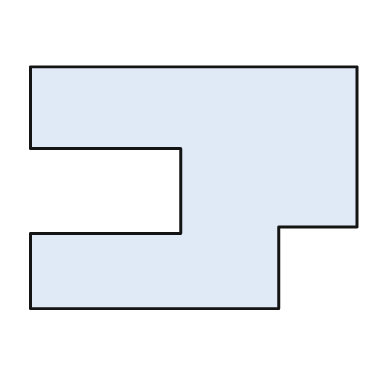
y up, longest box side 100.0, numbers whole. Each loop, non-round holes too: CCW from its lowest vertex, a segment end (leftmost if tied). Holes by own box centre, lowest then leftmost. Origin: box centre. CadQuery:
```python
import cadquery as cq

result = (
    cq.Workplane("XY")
    .moveTo(-50.0, -37.0)
    .lineTo(26.0, -37.0)
    .lineTo(26.0, -12.0)
    .lineTo(50.0, -12.0)
    .lineTo(50.0, 37.0)
    .lineTo(-50.0, 37.0)
    .lineTo(-50.0, 12.0)
    .lineTo(-4.0, 12.0)
    .lineTo(-4.0, -14.0)
    .lineTo(-50.0, -14.0)
    .close()
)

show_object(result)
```